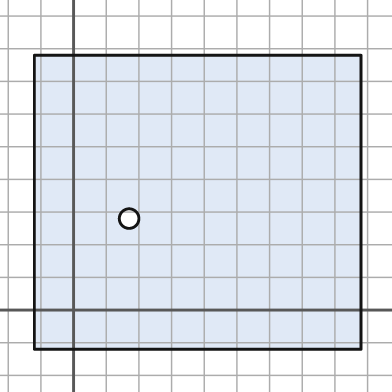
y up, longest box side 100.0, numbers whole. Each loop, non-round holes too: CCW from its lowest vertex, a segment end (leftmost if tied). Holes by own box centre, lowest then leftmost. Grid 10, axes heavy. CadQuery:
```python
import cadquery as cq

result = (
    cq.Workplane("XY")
    .moveTo(-12.0, -12.0)
    .lineTo(88.0, -12.0)
    .lineTo(88.0, 78.0)
    .lineTo(-12.0, 78.0)
    .close()
    .moveTo(17.0, 28.0)
    .circle(3.0)
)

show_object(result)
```